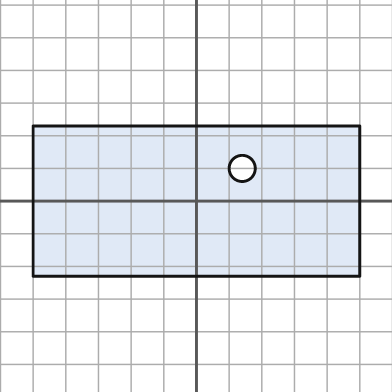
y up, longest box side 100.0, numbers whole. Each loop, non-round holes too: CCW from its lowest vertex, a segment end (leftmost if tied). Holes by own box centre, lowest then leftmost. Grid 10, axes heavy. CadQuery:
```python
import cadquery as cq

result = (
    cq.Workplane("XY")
    .moveTo(-50.0, -23.0)
    .lineTo(50.0, -23.0)
    .lineTo(50.0, 23.0)
    .lineTo(-50.0, 23.0)
    .close()
    .moveTo(14.0, 10.0)
    .circle(4.0)
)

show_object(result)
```